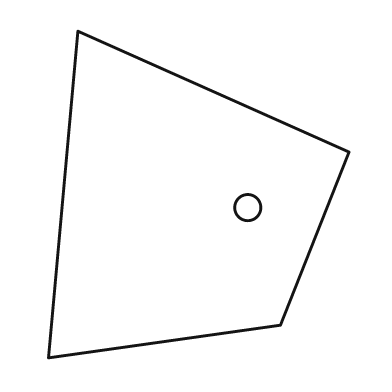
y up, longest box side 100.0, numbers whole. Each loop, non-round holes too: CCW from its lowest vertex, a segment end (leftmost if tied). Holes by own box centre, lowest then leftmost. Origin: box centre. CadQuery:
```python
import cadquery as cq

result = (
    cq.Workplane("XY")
    .moveTo(-46.0, -50.0)
    .lineTo(25.0, -40.0)
    .lineTo(46.0, 13.0)
    .lineTo(-37.0, 50.0)
    .close()
    .moveTo(15.0, -4.0)
    .circle(4.0)
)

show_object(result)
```